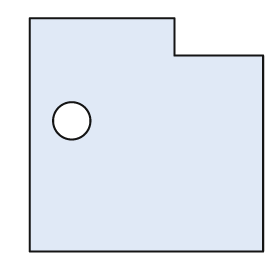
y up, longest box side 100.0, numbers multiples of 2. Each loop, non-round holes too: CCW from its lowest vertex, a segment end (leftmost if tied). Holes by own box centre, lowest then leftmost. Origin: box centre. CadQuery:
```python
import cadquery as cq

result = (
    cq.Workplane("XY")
    .moveTo(-50.0, -50.0)
    .lineTo(50.0, -50.0)
    .lineTo(50.0, 34.0)
    .lineTo(12.0, 34.0)
    .lineTo(12.0, 50.0)
    .lineTo(-50.0, 50.0)
    .close()
    .moveTo(-32.0, 6.0)
    .circle(8.0)
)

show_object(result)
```